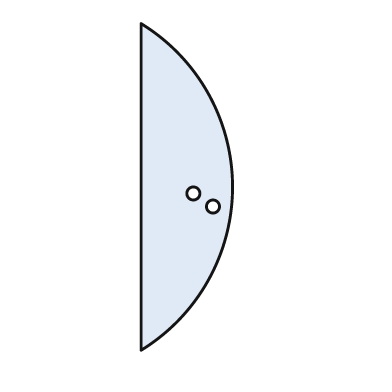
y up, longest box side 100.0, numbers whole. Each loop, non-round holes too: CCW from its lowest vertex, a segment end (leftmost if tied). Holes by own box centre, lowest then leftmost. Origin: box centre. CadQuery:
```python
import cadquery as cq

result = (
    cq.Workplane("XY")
    .moveTo(-14.0, -50.0)
    .threePointArc((14.0, 0.0), (-14.0, 50.0))
    .close()
    .moveTo(8.0, -6.0)
    .circle(2.0)
    .moveTo(2.0, -2.0)
    .circle(2.0)
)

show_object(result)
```